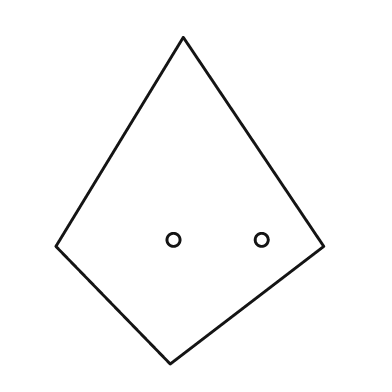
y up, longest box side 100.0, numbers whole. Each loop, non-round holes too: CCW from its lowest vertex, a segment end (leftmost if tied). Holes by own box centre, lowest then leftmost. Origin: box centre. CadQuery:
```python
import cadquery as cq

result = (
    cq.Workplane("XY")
    .moveTo(-6.0, -50.0)
    .lineTo(41.0, -14.0)
    .lineTo(-2.0, 50.0)
    .lineTo(-41.0, -14.0)
    .close()
    .moveTo(-5.0, -12.0)
    .circle(2.0)
    .moveTo(22.0, -12.0)
    .circle(2.0)
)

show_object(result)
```